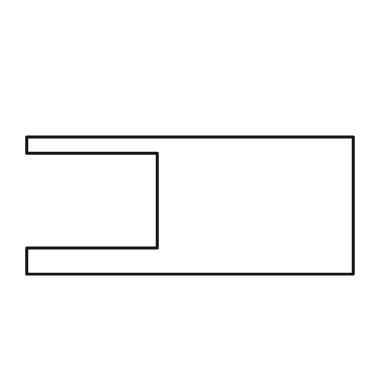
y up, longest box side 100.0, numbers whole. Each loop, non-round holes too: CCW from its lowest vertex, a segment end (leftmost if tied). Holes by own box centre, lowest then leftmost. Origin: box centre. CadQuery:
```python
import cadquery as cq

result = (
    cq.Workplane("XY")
    .moveTo(-50.0, -21.0)
    .lineTo(50.0, -21.0)
    .lineTo(50.0, 21.0)
    .lineTo(-50.0, 21.0)
    .lineTo(-50.0, 16.0)
    .lineTo(-10.0, 16.0)
    .lineTo(-10.0, -13.0)
    .lineTo(-50.0, -13.0)
    .close()
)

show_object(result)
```